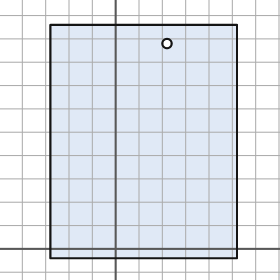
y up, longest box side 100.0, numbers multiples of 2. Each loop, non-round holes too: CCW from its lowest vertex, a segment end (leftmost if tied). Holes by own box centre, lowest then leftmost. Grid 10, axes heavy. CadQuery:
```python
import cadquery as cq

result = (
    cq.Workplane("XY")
    .moveTo(-28.0, -4.0)
    .lineTo(52.0, -4.0)
    .lineTo(52.0, 96.0)
    .lineTo(-28.0, 96.0)
    .close()
    .moveTo(22.0, 88.0)
    .circle(2.0)
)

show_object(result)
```